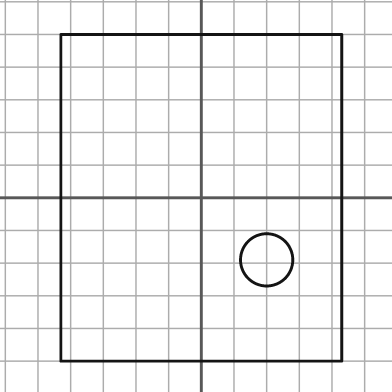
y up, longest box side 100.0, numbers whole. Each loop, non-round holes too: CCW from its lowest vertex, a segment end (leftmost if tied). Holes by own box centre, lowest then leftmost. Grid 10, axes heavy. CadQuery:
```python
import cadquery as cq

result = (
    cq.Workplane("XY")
    .moveTo(-43.0, -50.0)
    .lineTo(43.0, -50.0)
    .lineTo(43.0, 50.0)
    .lineTo(-43.0, 50.0)
    .close()
    .moveTo(20.0, -19.0)
    .circle(8.0)
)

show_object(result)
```